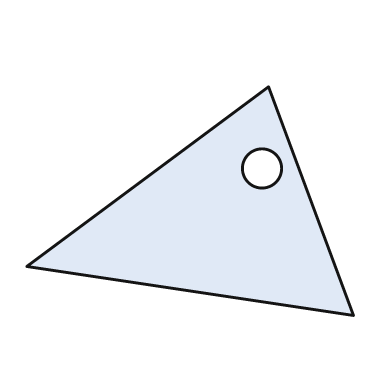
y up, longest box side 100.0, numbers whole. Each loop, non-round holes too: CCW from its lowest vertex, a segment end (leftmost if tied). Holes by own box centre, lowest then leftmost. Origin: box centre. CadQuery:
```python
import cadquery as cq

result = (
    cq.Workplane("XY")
    .moveTo(50.0, -35.0)
    .lineTo(24.0, 35.0)
    .lineTo(-50.0, -20.0)
    .close()
    .moveTo(22.0, 10.0)
    .circle(6.0)
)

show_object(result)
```